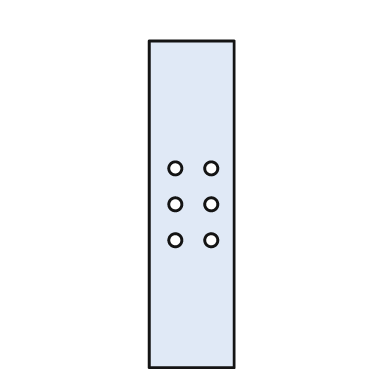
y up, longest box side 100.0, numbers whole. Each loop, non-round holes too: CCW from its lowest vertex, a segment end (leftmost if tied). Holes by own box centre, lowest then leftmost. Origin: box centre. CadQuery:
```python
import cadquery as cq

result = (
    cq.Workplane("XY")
    .moveTo(-13.0, -50.0)
    .lineTo(13.0, -50.0)
    .lineTo(13.0, 50.0)
    .lineTo(-13.0, 50.0)
    .close()
    .moveTo(-5.0, -11.0)
    .circle(2.0)
    .moveTo(6.0, -11.0)
    .circle(2.0)
    .moveTo(-5.0, 0.0)
    .circle(2.0)
    .moveTo(6.0, 0.0)
    .circle(2.0)
    .moveTo(-5.0, 11.0)
    .circle(2.0)
    .moveTo(6.0, 11.0)
    .circle(2.0)
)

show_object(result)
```